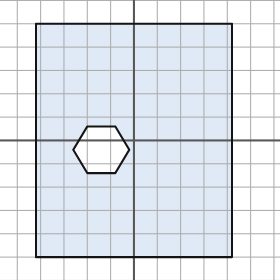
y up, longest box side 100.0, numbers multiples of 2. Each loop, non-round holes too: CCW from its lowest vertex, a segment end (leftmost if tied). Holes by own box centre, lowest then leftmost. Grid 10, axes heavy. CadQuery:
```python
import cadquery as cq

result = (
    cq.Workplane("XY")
    .moveTo(-42.0, -50.0)
    .lineTo(42.0, -50.0)
    .lineTo(42.0, 50.0)
    .lineTo(-42.0, 50.0)
    .close()
    .moveTo(-20.0, -14.0)
    .lineTo(-8.0, -14.0)
    .lineTo(-2.0, -4.0)
    .lineTo(-8.0, 6.0)
    .lineTo(-20.0, 6.0)
    .lineTo(-26.0, -4.0)
    .close()
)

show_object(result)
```